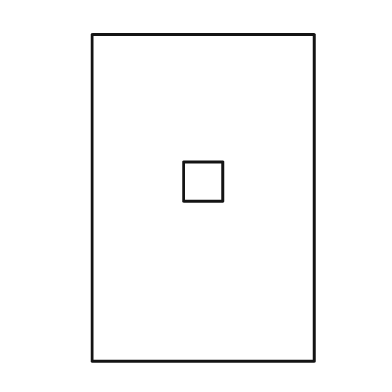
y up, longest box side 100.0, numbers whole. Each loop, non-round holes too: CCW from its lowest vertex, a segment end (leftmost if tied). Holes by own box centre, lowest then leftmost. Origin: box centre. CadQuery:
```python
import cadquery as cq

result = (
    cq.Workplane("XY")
    .moveTo(-34.0, -50.0)
    .lineTo(34.0, -50.0)
    .lineTo(34.0, 50.0)
    .lineTo(-34.0, 50.0)
    .close()
    .moveTo(-6.0, -1.0)
    .lineTo(6.0, -1.0)
    .lineTo(6.0, 11.0)
    .lineTo(-6.0, 11.0)
    .close()
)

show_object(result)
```